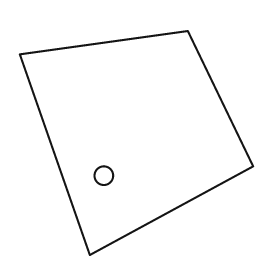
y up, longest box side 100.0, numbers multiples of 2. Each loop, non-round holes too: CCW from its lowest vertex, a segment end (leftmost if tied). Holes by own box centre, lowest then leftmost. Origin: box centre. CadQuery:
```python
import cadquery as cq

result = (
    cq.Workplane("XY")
    .moveTo(-20.0, -48.0)
    .lineTo(50.0, -10.0)
    .lineTo(22.0, 48.0)
    .lineTo(-50.0, 38.0)
    .close()
    .moveTo(-14.0, -14.0)
    .circle(4.0)
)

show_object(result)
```